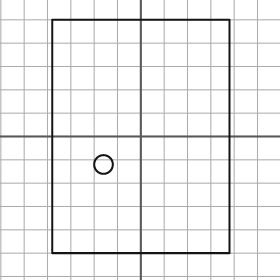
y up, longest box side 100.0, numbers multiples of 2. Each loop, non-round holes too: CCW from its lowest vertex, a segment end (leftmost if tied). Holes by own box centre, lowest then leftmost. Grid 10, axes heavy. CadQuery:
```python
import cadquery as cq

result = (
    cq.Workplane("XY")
    .moveTo(-38.0, -50.0)
    .lineTo(38.0, -50.0)
    .lineTo(38.0, 50.0)
    .lineTo(-38.0, 50.0)
    .close()
    .moveTo(-16.0, -12.0)
    .circle(4.0)
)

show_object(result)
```